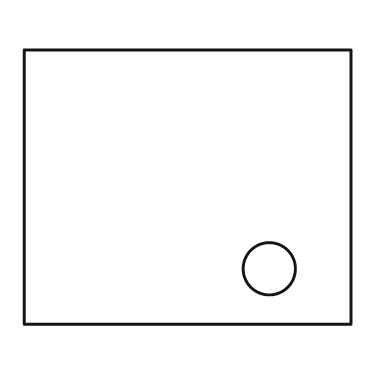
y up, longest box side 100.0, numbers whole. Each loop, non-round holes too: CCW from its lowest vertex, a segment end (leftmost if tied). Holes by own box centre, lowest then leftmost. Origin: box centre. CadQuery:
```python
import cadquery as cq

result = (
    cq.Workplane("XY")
    .moveTo(-50.0, -42.0)
    .lineTo(50.0, -42.0)
    .lineTo(50.0, 42.0)
    .lineTo(-50.0, 42.0)
    .close()
    .moveTo(25.0, -25.0)
    .circle(8.0)
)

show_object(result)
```